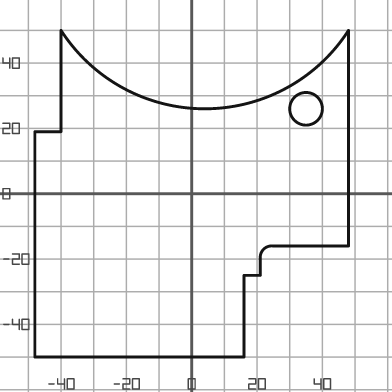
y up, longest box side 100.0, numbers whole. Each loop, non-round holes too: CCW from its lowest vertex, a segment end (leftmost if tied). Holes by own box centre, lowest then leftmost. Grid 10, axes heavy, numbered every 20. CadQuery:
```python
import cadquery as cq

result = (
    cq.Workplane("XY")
    .moveTo(-48.0, -50.0)
    .lineTo(16.0, -50.0)
    .lineTo(16.0, -25.0)
    .lineTo(21.0, -25.0)
    .lineTo(21.0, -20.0)
    .threePointArc((22.0, -17.0), (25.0, -16.0))
    .lineTo(48.0, -16.0)
    .lineTo(48.0, 50.0)
    .threePointArc((4.0, 26.0), (-40.0, 50.0))
    .lineTo(-40.0, 19.0)
    .lineTo(-48.0, 19.0)
    .close()
    .moveTo(35.0, 26.0)
    .circle(5.0)
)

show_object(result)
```